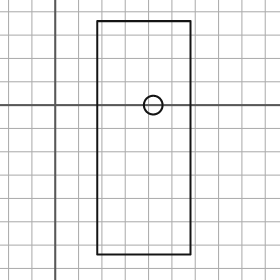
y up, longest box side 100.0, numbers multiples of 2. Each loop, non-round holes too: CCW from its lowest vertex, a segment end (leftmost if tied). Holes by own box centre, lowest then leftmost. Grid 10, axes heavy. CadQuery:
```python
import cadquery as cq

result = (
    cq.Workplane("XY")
    .moveTo(18.0, -64.0)
    .lineTo(58.0, -64.0)
    .lineTo(58.0, 36.0)
    .lineTo(18.0, 36.0)
    .close()
    .moveTo(42.0, 0.0)
    .circle(4.0)
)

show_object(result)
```